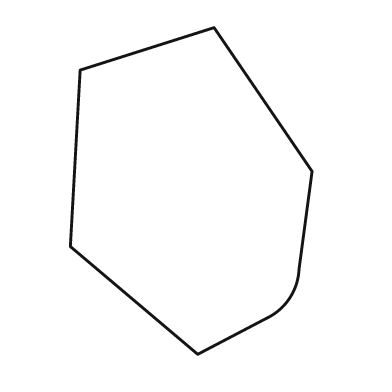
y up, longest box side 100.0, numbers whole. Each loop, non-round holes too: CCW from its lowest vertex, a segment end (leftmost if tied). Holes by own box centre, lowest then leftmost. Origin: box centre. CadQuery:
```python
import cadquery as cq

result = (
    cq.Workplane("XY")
    .moveTo(2.0, -50.0)
    .lineTo(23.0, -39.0)
    .threePointArc((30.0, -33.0), (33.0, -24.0))
    .lineTo(37.0, 6.0)
    .lineTo(7.0, 50.0)
    .lineTo(-34.0, 37.0)
    .lineTo(-37.0, -17.0)
    .close()
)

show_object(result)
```